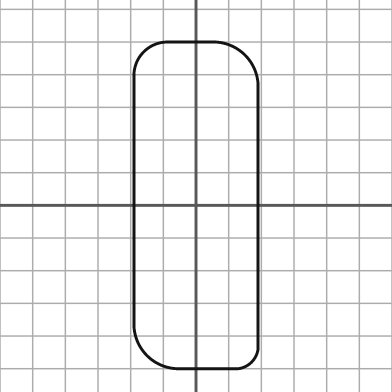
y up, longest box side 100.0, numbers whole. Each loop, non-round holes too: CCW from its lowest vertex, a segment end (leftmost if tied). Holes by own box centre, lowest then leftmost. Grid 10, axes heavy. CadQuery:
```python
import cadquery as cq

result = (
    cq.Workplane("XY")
    .moveTo(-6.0, -50.0)
    .lineTo(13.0, -50.0)
    .threePointArc((17.0, -48.0), (19.0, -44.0))
    .lineTo(19.0, 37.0)
    .threePointArc((15.0, 46.0), (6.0, 50.0))
    .lineTo(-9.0, 50.0)
    .threePointArc((-16.0, 47.0), (-19.0, 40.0))
    .lineTo(-19.0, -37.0)
    .threePointArc((-15.0, -46.0), (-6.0, -50.0))
    .close()
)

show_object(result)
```